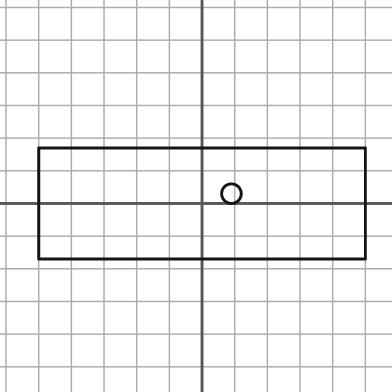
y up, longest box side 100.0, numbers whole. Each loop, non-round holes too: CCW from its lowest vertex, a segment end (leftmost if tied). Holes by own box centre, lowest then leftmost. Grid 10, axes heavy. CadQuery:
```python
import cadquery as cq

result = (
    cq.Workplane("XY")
    .moveTo(-50.0, -17.0)
    .lineTo(50.0, -17.0)
    .lineTo(50.0, 17.0)
    .lineTo(-50.0, 17.0)
    .close()
    .moveTo(9.0, 3.0)
    .circle(3.0)
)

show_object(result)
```